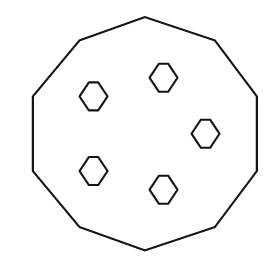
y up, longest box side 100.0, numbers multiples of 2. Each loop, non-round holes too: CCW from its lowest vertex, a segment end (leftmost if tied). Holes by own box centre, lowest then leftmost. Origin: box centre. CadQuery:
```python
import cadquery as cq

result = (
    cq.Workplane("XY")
    .moveTo(0.0, -50.0)
    .lineTo(30.0, -40.0)
    .lineTo(48.0, -16.0)
    .lineTo(48.0, 16.0)
    .lineTo(30.0, 40.0)
    .lineTo(0.0, 50.0)
    .lineTo(-28.0, 40.0)
    .lineTo(-48.0, 16.0)
    .lineTo(-48.0, -16.0)
    .lineTo(-28.0, -40.0)
    .close()
    .moveTo(6.0, -30.0)
    .lineTo(10.0, -30.0)
    .lineTo(14.0, -24.0)
    .lineTo(10.0, -18.0)
    .lineTo(6.0, -18.0)
    .lineTo(2.0, -24.0)
    .close()
    .moveTo(-24.0, -22.0)
    .lineTo(-20.0, -22.0)
    .lineTo(-16.0, -16.0)
    .lineTo(-20.0, -10.0)
    .lineTo(-24.0, -10.0)
    .lineTo(-28.0, -16.0)
    .close()
    .moveTo(24.0, -6.0)
    .lineTo(28.0, -6.0)
    .lineTo(32.0, 0.0)
    .lineTo(28.0, 6.0)
    .lineTo(24.0, 6.0)
    .lineTo(20.0, 0.0)
    .close()
    .moveTo(-24.0, 10.0)
    .lineTo(-20.0, 10.0)
    .lineTo(-16.0, 16.0)
    .lineTo(-20.0, 22.0)
    .lineTo(-24.0, 22.0)
    .lineTo(-28.0, 16.0)
    .close()
    .moveTo(6.0, 18.0)
    .lineTo(10.0, 18.0)
    .lineTo(14.0, 24.0)
    .lineTo(10.0, 30.0)
    .lineTo(6.0, 30.0)
    .lineTo(2.0, 24.0)
    .close()
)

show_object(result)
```